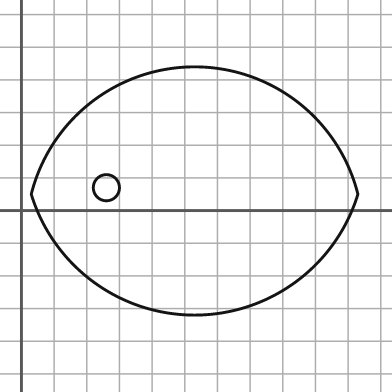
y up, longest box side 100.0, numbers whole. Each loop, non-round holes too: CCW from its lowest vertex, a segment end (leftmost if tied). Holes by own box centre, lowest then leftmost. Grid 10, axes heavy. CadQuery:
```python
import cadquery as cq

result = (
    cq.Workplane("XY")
    .moveTo(3.0, 5.0)
    .threePointArc((53.0, -32.0), (103.0, 5.0))
    .threePointArc((53.0, 44.0), (3.0, 5.0))
    .close()
    .moveTo(26.0, 7.0)
    .circle(4.0)
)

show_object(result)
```